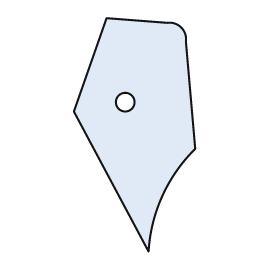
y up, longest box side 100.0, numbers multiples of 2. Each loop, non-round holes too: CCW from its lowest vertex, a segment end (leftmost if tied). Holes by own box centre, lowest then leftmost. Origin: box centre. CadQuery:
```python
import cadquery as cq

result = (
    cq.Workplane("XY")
    .moveTo(6.0, -50.0)
    .threePointArc((12.0, -26.0), (26.0, -6.0))
    .lineTo(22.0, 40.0)
    .threePointArc((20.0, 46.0), (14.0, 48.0))
    .lineTo(-12.0, 50.0)
    .lineTo(-26.0, 10.0)
    .close()
    .moveTo(-4.0, 14.0)
    .circle(4.0)
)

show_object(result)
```